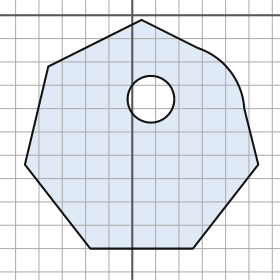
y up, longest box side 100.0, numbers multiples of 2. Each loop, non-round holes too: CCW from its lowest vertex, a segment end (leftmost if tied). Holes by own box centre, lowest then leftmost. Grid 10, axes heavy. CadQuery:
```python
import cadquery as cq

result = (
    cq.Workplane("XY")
    .moveTo(-18.0, -100.0)
    .lineTo(26.0, -100.0)
    .lineTo(54.0, -64.0)
    .lineTo(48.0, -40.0)
    .threePointArc((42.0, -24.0), (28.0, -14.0))
    .lineTo(4.0, -2.0)
    .lineTo(-36.0, -22.0)
    .lineTo(-46.0, -64.0)
    .close()
    .moveTo(8.0, -36.0)
    .circle(10.0)
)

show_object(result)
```